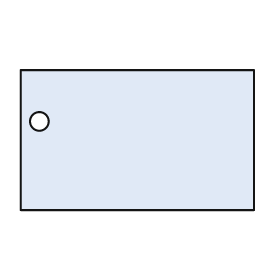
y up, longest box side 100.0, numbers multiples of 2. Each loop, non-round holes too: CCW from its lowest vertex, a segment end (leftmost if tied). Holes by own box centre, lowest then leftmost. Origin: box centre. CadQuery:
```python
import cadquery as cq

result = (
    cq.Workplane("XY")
    .moveTo(-50.0, -30.0)
    .lineTo(50.0, -30.0)
    .lineTo(50.0, 30.0)
    .lineTo(-50.0, 30.0)
    .close()
    .moveTo(-42.0, 8.0)
    .circle(4.0)
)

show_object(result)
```